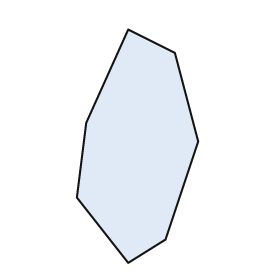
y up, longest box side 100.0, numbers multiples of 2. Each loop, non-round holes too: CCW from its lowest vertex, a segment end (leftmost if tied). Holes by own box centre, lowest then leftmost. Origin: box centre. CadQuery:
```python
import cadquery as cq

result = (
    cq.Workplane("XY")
    .moveTo(-4.0, -50.0)
    .lineTo(12.0, -40.0)
    .lineTo(26.0, 2.0)
    .lineTo(16.0, 40.0)
    .lineTo(-4.0, 50.0)
    .lineTo(-22.0, 10.0)
    .lineTo(-26.0, -22.0)
    .close()
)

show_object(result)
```